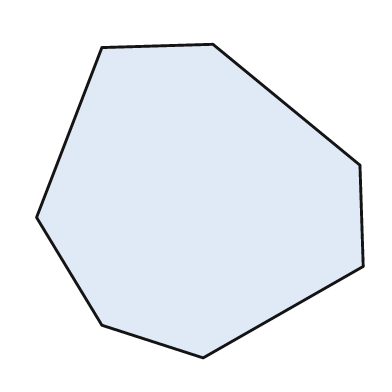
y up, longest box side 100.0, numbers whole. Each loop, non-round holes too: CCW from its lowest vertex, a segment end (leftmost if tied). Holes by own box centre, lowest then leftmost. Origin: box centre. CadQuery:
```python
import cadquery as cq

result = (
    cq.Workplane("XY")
    .moveTo(1.0, -48.0)
    .lineTo(50.0, -20.0)
    .lineTo(49.0, 11.0)
    .lineTo(4.0, 48.0)
    .lineTo(-30.0, 47.0)
    .lineTo(-50.0, -5.0)
    .lineTo(-30.0, -38.0)
    .close()
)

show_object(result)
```